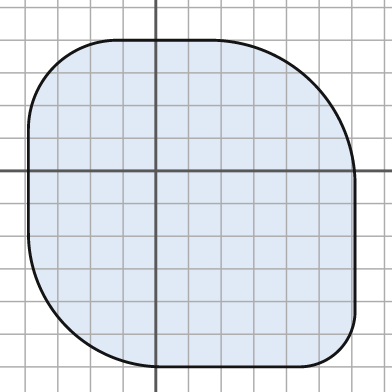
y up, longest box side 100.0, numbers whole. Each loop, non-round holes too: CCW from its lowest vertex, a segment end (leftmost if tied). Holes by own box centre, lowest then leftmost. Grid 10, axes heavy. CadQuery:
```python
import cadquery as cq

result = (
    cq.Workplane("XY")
    .moveTo(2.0, -60.0)
    .lineTo(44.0, -60.0)
    .threePointArc((56.0, -55.0), (61.0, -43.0))
    .lineTo(61.0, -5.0)
    .threePointArc((48.0, 27.0), (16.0, 40.0))
    .lineTo(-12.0, 40.0)
    .threePointArc((-31.0, 32.0), (-39.0, 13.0))
    .lineTo(-39.0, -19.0)
    .threePointArc((-27.0, -48.0), (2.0, -60.0))
    .close()
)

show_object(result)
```